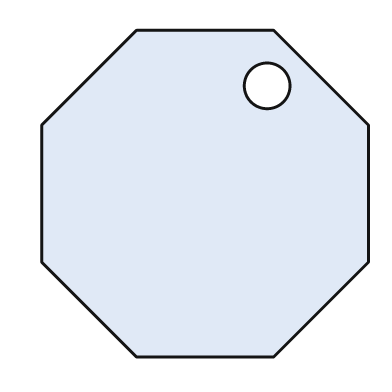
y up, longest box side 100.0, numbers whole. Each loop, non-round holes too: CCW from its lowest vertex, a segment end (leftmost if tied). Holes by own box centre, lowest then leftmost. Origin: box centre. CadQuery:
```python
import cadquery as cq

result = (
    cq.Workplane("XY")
    .moveTo(-21.0, -50.0)
    .lineTo(21.0, -50.0)
    .lineTo(50.0, -21.0)
    .lineTo(50.0, 21.0)
    .lineTo(21.0, 50.0)
    .lineTo(-21.0, 50.0)
    .lineTo(-50.0, 21.0)
    .lineTo(-50.0, -21.0)
    .close()
    .moveTo(19.0, 33.0)
    .circle(7.0)
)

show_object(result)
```